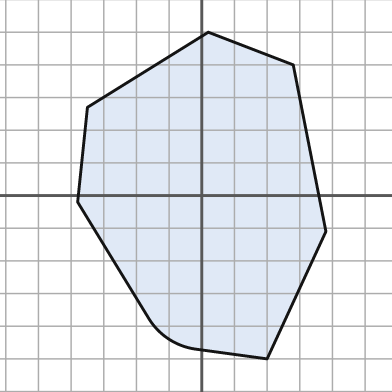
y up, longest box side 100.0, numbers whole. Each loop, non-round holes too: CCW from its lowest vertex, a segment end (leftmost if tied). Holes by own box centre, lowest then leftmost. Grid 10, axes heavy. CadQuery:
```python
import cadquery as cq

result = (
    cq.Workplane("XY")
    .moveTo(20.0, -50.0)
    .lineTo(38.0, -11.0)
    .lineTo(28.0, 40.0)
    .lineTo(2.0, 50.0)
    .lineTo(-35.0, 27.0)
    .lineTo(-38.0, -2.0)
    .lineTo(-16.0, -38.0)
    .threePointArc((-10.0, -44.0), (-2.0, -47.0))
    .close()
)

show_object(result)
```